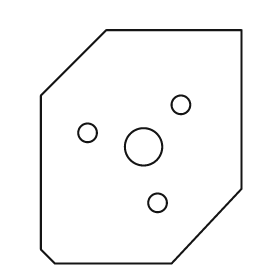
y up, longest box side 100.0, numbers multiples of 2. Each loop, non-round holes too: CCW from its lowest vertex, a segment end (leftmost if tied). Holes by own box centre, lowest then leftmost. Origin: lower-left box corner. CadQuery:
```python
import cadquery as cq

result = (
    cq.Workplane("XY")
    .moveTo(6.0, 0.0)
    .lineTo(56.0, 0.0)
    .lineTo(86.0, 32.0)
    .lineTo(86.0, 100.0)
    .lineTo(28.0, 100.0)
    .lineTo(0.0, 72.0)
    .lineTo(0.0, 6.0)
    .close()
    .moveTo(50.0, 26.0)
    .circle(4.0)
    .moveTo(44.0, 50.0)
    .circle(8.0)
    .moveTo(20.0, 56.0)
    .circle(4.0)
    .moveTo(60.0, 68.0)
    .circle(4.0)
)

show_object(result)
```